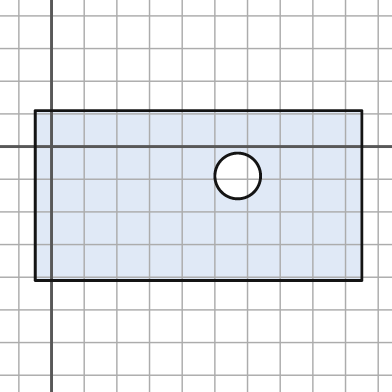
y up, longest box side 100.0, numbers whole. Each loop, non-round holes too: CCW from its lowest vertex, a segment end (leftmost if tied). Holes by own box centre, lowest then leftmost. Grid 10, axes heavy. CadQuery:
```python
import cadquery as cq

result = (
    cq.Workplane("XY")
    .moveTo(-5.0, -41.0)
    .lineTo(95.0, -41.0)
    .lineTo(95.0, 11.0)
    .lineTo(-5.0, 11.0)
    .close()
    .moveTo(57.0, -9.0)
    .circle(7.0)
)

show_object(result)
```